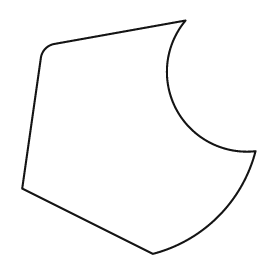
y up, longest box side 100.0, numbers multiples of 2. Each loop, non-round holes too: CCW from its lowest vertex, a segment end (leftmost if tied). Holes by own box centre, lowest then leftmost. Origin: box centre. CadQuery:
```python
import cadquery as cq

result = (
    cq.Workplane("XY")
    .moveTo(6.0, -50.0)
    .threePointArc((34.0, -34.0), (50.0, -6.0))
    .threePointArc((16.0, 12.0), (20.0, 50.0))
    .lineTo(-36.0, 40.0)
    .threePointArc((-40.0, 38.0), (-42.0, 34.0))
    .lineTo(-50.0, -22.0)
    .close()
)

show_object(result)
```